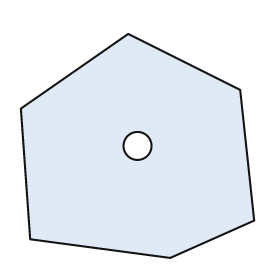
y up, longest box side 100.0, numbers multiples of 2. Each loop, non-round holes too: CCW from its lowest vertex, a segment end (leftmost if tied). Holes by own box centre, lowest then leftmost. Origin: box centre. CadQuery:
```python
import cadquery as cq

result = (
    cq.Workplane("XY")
    .moveTo(14.0, -48.0)
    .lineTo(50.0, -32.0)
    .lineTo(44.0, 24.0)
    .lineTo(-4.0, 48.0)
    .lineTo(-50.0, 16.0)
    .lineTo(-46.0, -40.0)
    .close()
    .moveTo(0.0, 0.0)
    .circle(6.0)
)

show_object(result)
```